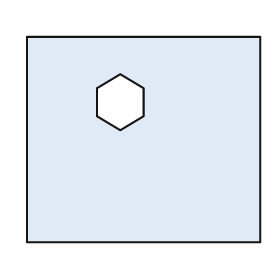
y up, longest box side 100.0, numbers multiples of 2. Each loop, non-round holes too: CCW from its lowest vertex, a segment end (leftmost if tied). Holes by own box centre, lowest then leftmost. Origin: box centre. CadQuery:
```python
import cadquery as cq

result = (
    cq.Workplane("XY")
    .moveTo(-50.0, -44.0)
    .lineTo(50.0, -44.0)
    .lineTo(50.0, 44.0)
    .lineTo(-50.0, 44.0)
    .close()
    .moveTo(-10.0, 4.0)
    .lineTo(0.0, 10.0)
    .lineTo(0.0, 22.0)
    .lineTo(-10.0, 28.0)
    .lineTo(-20.0, 22.0)
    .lineTo(-20.0, 10.0)
    .close()
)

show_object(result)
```